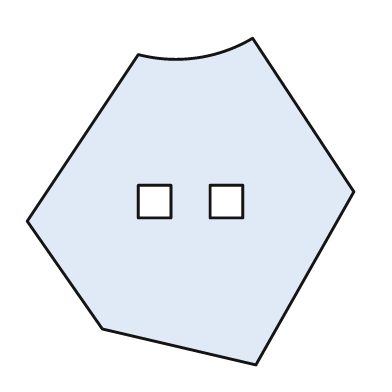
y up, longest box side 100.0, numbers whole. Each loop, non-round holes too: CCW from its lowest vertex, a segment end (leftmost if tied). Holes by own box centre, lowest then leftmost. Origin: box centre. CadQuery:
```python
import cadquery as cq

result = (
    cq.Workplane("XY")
    .moveTo(20.0, -50.0)
    .lineTo(50.0, 3.0)
    .lineTo(19.0, 50.0)
    .threePointArc((2.0, 44.0), (-16.0, 45.0))
    .lineTo(-50.0, -6.0)
    .lineTo(-27.0, -39.0)
    .close()
    .moveTo(-16.0, -5.0)
    .lineTo(-6.0, -5.0)
    .lineTo(-6.0, 5.0)
    .lineTo(-16.0, 5.0)
    .close()
    .moveTo(6.0, -5.0)
    .lineTo(16.0, -5.0)
    .lineTo(16.0, 5.0)
    .lineTo(6.0, 5.0)
    .close()
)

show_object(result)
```